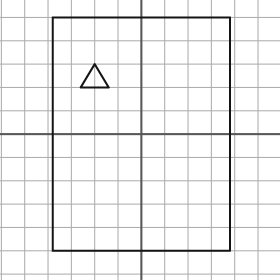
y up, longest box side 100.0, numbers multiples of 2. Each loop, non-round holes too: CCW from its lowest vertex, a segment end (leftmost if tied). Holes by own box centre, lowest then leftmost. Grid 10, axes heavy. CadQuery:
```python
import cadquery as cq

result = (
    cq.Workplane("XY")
    .moveTo(-38.0, -50.0)
    .lineTo(38.0, -50.0)
    .lineTo(38.0, 50.0)
    .lineTo(-38.0, 50.0)
    .close()
    .moveTo(-26.0, 20.0)
    .lineTo(-14.0, 20.0)
    .lineTo(-20.0, 30.0)
    .close()
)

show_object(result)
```